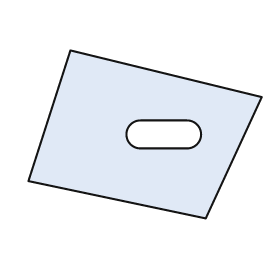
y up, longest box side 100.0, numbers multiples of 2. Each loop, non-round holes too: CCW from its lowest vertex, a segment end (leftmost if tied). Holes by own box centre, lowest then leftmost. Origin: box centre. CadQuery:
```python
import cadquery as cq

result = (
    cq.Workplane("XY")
    .moveTo(26.0, -36.0)
    .lineTo(50.0, 16.0)
    .lineTo(-32.0, 36.0)
    .lineTo(-50.0, -20.0)
    .close()
    .moveTo(-2.0, -6.0)
    .lineTo(18.0, -6.0)
    .threePointArc((24.0, 0.0), (18.0, 6.0))
    .lineTo(-2.0, 6.0)
    .threePointArc((-8.0, 0.0), (-2.0, -6.0))
    .close()
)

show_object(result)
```